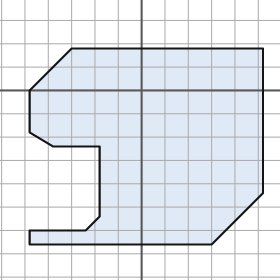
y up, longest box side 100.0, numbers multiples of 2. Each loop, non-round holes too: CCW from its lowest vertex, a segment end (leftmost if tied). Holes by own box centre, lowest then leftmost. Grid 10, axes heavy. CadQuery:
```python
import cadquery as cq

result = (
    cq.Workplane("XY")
    .moveTo(-48.0, -66.0)
    .lineTo(30.0, -66.0)
    .lineTo(52.0, -44.0)
    .lineTo(52.0, 18.0)
    .lineTo(-30.0, 18.0)
    .lineTo(-48.0, 0.0)
    .lineTo(-48.0, -18.0)
    .lineTo(-38.0, -24.0)
    .lineTo(-18.0, -24.0)
    .lineTo(-18.0, -54.0)
    .lineTo(-24.0, -60.0)
    .lineTo(-48.0, -60.0)
    .close()
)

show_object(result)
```